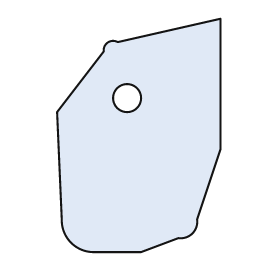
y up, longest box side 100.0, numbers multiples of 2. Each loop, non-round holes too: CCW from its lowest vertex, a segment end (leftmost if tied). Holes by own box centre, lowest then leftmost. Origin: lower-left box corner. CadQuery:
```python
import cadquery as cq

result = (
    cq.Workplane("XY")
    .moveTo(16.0, 0.0)
    .lineTo(36.0, 0.0)
    .lineTo(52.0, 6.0)
    .threePointArc((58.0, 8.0), (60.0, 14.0))
    .lineTo(70.0, 44.0)
    .lineTo(70.0, 100.0)
    .lineTo(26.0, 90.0)
    .threePointArc((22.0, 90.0), (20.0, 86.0))
    .lineTo(0.0, 60.0)
    .lineTo(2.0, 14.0)
    .threePointArc((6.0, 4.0), (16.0, 0.0))
    .close()
    .moveTo(30.0, 66.0)
    .circle(6.0)
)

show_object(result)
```